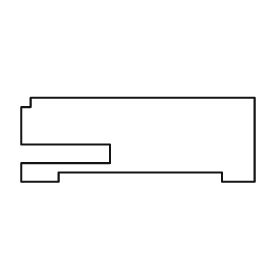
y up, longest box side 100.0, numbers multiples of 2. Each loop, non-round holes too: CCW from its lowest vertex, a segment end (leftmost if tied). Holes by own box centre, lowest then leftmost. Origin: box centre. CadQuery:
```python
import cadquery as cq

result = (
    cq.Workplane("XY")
    .moveTo(-50.0, -18.0)
    .lineTo(-34.0, -18.0)
    .lineTo(-34.0, -14.0)
    .lineTo(36.0, -14.0)
    .lineTo(36.0, -18.0)
    .lineTo(50.0, -18.0)
    .lineTo(50.0, 18.0)
    .lineTo(-46.0, 18.0)
    .lineTo(-46.0, 14.0)
    .lineTo(-50.0, 14.0)
    .lineTo(-50.0, -2.0)
    .lineTo(-12.0, -2.0)
    .lineTo(-12.0, -10.0)
    .lineTo(-50.0, -10.0)
    .close()
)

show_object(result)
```